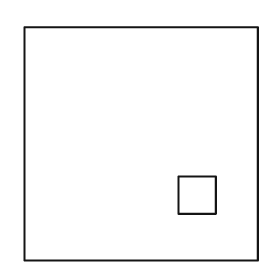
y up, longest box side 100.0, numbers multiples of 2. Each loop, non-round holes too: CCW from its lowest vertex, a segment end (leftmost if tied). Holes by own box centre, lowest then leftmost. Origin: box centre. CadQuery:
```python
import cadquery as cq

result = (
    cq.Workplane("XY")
    .moveTo(-50.0, -50.0)
    .lineTo(50.0, -50.0)
    .lineTo(50.0, 50.0)
    .lineTo(-50.0, 50.0)
    .close()
    .moveTo(16.0, -30.0)
    .lineTo(32.0, -30.0)
    .lineTo(32.0, -14.0)
    .lineTo(16.0, -14.0)
    .close()
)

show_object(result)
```